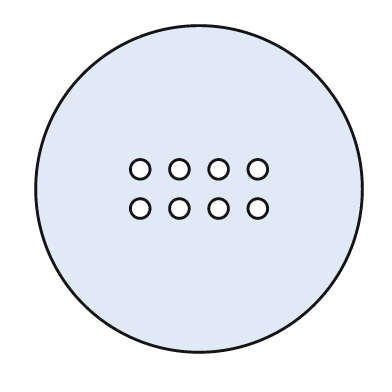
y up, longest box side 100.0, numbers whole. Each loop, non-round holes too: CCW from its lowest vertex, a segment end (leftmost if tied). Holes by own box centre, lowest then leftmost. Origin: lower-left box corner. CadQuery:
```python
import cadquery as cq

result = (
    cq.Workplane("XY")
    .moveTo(50.0, 50.0)
    .circle(50.0)
    .moveTo(32.0, 44.0)
    .circle(3.0)
    .moveTo(44.0, 44.0)
    .circle(3.0)
    .moveTo(56.0, 44.0)
    .circle(3.0)
    .moveTo(68.0, 44.0)
    .circle(3.0)
    .moveTo(32.0, 56.0)
    .circle(3.0)
    .moveTo(44.0, 56.0)
    .circle(3.0)
    .moveTo(56.0, 56.0)
    .circle(3.0)
    .moveTo(68.0, 56.0)
    .circle(3.0)
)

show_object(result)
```